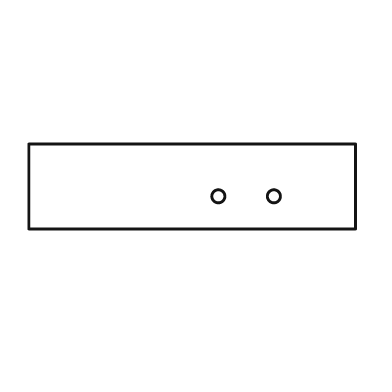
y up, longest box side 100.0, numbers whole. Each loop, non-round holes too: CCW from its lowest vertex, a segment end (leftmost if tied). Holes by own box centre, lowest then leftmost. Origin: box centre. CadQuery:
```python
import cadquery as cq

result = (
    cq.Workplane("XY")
    .moveTo(-50.0, -13.0)
    .lineTo(50.0, -13.0)
    .lineTo(50.0, 13.0)
    .lineTo(-50.0, 13.0)
    .close()
    .moveTo(8.0, -3.0)
    .circle(2.0)
    .moveTo(25.0, -3.0)
    .circle(2.0)
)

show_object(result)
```